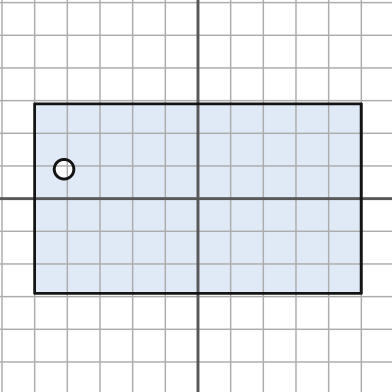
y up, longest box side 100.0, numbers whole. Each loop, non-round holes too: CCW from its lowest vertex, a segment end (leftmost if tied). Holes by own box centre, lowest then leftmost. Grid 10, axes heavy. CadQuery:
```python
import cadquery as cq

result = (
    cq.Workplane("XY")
    .moveTo(-50.0, -29.0)
    .lineTo(50.0, -29.0)
    .lineTo(50.0, 29.0)
    .lineTo(-50.0, 29.0)
    .close()
    .moveTo(-41.0, 9.0)
    .circle(3.0)
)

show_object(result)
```